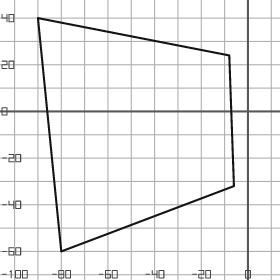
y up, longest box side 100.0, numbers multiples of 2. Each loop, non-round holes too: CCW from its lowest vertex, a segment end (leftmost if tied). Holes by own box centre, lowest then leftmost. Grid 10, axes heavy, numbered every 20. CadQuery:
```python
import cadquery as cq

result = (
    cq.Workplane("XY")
    .moveTo(-80.0, -60.0)
    .lineTo(-6.0, -32.0)
    .lineTo(-8.0, 24.0)
    .lineTo(-90.0, 40.0)
    .close()
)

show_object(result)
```